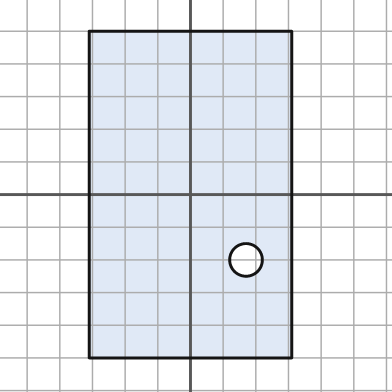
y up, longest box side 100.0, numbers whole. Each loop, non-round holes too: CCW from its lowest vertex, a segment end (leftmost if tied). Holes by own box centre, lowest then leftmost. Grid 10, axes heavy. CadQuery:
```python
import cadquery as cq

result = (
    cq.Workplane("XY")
    .moveTo(-31.0, -50.0)
    .lineTo(31.0, -50.0)
    .lineTo(31.0, 50.0)
    .lineTo(-31.0, 50.0)
    .close()
    .moveTo(17.0, -20.0)
    .circle(5.0)
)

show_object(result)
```